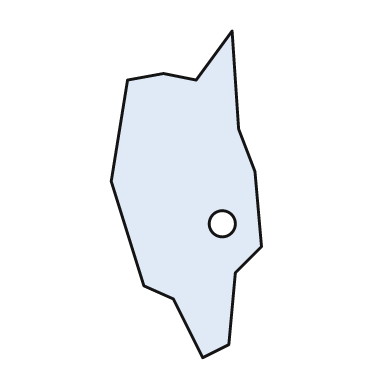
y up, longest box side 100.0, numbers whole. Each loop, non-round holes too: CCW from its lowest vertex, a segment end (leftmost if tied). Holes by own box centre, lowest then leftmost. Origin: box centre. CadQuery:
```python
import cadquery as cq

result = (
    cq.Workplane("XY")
    .moveTo(5.0, -50.0)
    .lineTo(13.0, -46.0)
    .lineTo(15.0, -24.0)
    .lineTo(23.0, -16.0)
    .lineTo(21.0, 7.0)
    .lineTo(16.0, 20.0)
    .lineTo(14.0, 50.0)
    .lineTo(3.0, 35.0)
    .lineTo(-7.0, 37.0)
    .lineTo(-18.0, 35.0)
    .lineTo(-23.0, 4.0)
    .lineTo(-13.0, -28.0)
    .lineTo(-4.0, -32.0)
    .close()
    .moveTo(11.0, -9.0)
    .circle(4.0)
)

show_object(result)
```